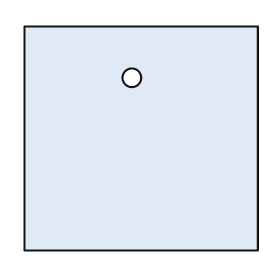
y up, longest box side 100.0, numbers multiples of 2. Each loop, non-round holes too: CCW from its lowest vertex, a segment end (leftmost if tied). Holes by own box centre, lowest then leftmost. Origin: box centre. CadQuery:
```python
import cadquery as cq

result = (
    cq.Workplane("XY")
    .moveTo(-50.0, -48.0)
    .lineTo(50.0, -48.0)
    .lineTo(50.0, 48.0)
    .lineTo(-50.0, 48.0)
    .close()
    .moveTo(-4.0, 26.0)
    .circle(4.0)
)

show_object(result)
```